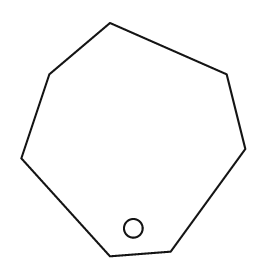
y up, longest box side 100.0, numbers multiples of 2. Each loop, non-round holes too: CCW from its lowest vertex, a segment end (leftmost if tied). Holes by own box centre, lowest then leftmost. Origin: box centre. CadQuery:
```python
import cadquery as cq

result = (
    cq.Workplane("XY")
    .moveTo(-10.0, -50.0)
    .lineTo(16.0, -48.0)
    .lineTo(48.0, -4.0)
    .lineTo(40.0, 28.0)
    .lineTo(-10.0, 50.0)
    .lineTo(-36.0, 28.0)
    .lineTo(-48.0, -8.0)
    .close()
    .moveTo(0.0, -38.0)
    .circle(4.0)
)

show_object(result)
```